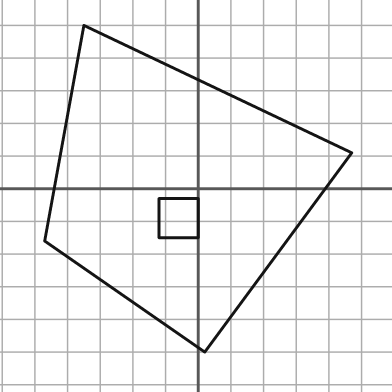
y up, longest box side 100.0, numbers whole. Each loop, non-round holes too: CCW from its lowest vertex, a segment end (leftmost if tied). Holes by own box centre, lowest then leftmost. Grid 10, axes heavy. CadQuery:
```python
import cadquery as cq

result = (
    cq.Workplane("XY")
    .moveTo(2.0, -50.0)
    .lineTo(47.0, 11.0)
    .lineTo(-35.0, 50.0)
    .lineTo(-47.0, -16.0)
    .close()
    .moveTo(-12.0, -15.0)
    .lineTo(0.0, -15.0)
    .lineTo(0.0, -3.0)
    .lineTo(-12.0, -3.0)
    .close()
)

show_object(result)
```